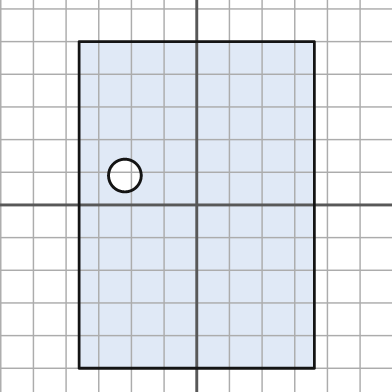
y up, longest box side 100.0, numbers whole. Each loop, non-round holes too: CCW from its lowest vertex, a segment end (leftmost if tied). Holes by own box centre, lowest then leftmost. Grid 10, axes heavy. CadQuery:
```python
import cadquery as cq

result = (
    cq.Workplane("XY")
    .moveTo(-36.0, -50.0)
    .lineTo(36.0, -50.0)
    .lineTo(36.0, 50.0)
    .lineTo(-36.0, 50.0)
    .close()
    .moveTo(-22.0, 9.0)
    .circle(5.0)
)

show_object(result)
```